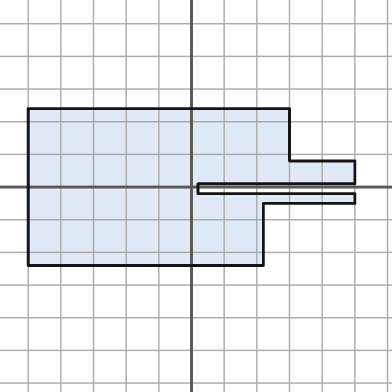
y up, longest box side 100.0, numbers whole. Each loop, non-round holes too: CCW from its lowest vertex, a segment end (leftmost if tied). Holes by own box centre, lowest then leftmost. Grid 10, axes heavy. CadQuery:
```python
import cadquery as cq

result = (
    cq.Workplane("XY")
    .moveTo(-50.0, -24.0)
    .lineTo(22.0, -24.0)
    .lineTo(22.0, -5.0)
    .lineTo(50.0, -5.0)
    .lineTo(50.0, -2.0)
    .lineTo(2.0, -2.0)
    .lineTo(2.0, 1.0)
    .lineTo(50.0, 1.0)
    .lineTo(50.0, 8.0)
    .lineTo(30.0, 8.0)
    .lineTo(30.0, 24.0)
    .lineTo(-50.0, 24.0)
    .close()
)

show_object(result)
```